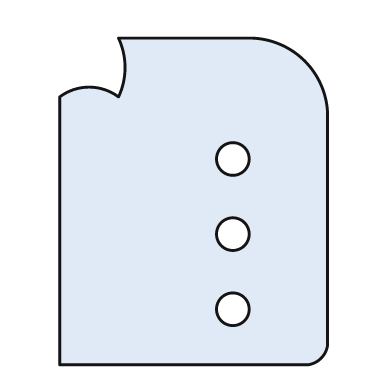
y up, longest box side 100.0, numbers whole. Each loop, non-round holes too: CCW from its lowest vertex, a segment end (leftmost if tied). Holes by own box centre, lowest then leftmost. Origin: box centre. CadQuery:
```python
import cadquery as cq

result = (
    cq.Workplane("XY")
    .moveTo(-41.0, -50.0)
    .lineTo(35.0, -50.0)
    .threePointArc((39.0, -48.0), (41.0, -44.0))
    .lineTo(41.0, 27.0)
    .threePointArc((34.0, 43.0), (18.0, 50.0))
    .lineTo(-23.0, 50.0)
    .threePointArc((-21.0, 41.0), (-23.0, 32.0))
    .threePointArc((-32.0, 35.0), (-41.0, 32.0))
    .close()
    .moveTo(12.0, -33.0)
    .circle(5.0)
    .moveTo(12.0, -10.0)
    .circle(5.0)
    .moveTo(12.0, 13.0)
    .circle(5.0)
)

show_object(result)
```